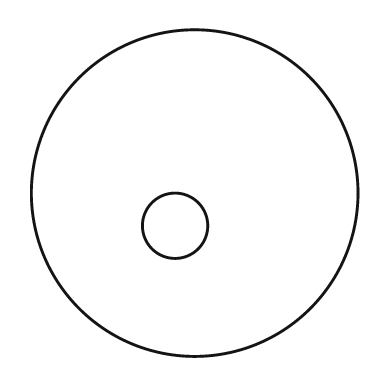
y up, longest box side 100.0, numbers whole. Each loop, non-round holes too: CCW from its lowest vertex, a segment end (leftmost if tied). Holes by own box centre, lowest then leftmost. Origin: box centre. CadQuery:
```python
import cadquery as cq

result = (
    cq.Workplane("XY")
    .moveTo(0.0, 0.0)
    .circle(50.0)
    .moveTo(-6.0, -10.0)
    .circle(10.0)
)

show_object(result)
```